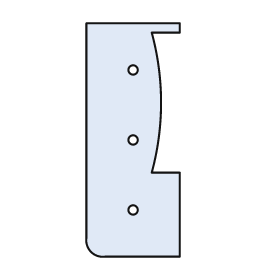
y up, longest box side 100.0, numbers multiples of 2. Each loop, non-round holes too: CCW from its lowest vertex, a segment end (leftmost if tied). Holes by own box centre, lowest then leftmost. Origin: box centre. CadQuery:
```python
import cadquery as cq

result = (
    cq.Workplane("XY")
    .moveTo(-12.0, -50.0)
    .lineTo(20.0, -50.0)
    .lineTo(20.0, -14.0)
    .lineTo(8.0, -14.0)
    .threePointArc((12.0, 16.0), (8.0, 46.0))
    .lineTo(20.0, 46.0)
    .lineTo(20.0, 50.0)
    .lineTo(-20.0, 50.0)
    .lineTo(-20.0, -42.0)
    .threePointArc((-18.0, -48.0), (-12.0, -50.0))
    .close()
    .moveTo(0.0, -30.0)
    .circle(2.0)
    .moveTo(0.0, 0.0)
    .circle(2.0)
    .moveTo(0.0, 30.0)
    .circle(2.0)
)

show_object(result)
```